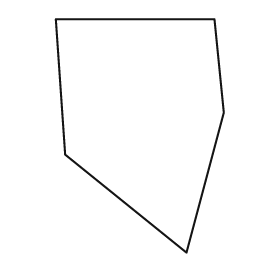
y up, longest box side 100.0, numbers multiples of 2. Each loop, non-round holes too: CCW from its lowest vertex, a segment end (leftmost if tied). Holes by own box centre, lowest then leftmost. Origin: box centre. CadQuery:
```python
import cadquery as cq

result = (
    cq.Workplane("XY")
    .moveTo(20.0, -50.0)
    .lineTo(36.0, 10.0)
    .lineTo(32.0, 50.0)
    .lineTo(-36.0, 50.0)
    .lineTo(-32.0, -8.0)
    .close()
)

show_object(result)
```